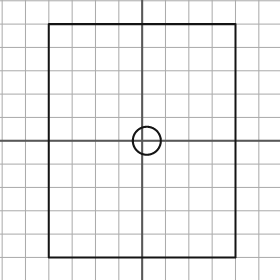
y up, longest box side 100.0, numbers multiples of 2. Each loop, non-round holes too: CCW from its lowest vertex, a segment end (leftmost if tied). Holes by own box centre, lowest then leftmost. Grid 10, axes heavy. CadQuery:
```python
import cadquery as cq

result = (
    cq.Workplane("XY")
    .moveTo(-40.0, -50.0)
    .lineTo(40.0, -50.0)
    .lineTo(40.0, 50.0)
    .lineTo(-40.0, 50.0)
    .close()
    .moveTo(2.0, 0.0)
    .circle(6.0)
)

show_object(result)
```